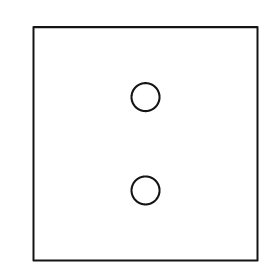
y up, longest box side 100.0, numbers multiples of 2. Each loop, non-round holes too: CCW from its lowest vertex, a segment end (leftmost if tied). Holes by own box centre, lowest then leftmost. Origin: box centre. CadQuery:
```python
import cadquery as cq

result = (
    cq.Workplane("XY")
    .moveTo(-48.0, -50.0)
    .lineTo(48.0, -50.0)
    .lineTo(48.0, 50.0)
    .lineTo(-48.0, 50.0)
    .close()
    .moveTo(0.0, -20.0)
    .circle(6.0)
    .moveTo(0.0, 20.0)
    .circle(6.0)
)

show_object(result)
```